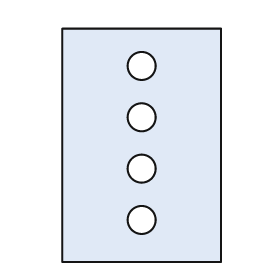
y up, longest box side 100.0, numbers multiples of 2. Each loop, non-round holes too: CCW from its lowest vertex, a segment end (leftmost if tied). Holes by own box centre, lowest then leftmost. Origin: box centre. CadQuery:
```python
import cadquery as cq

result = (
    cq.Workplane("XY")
    .moveTo(-34.0, -50.0)
    .lineTo(34.0, -50.0)
    .lineTo(34.0, 50.0)
    .lineTo(-34.0, 50.0)
    .close()
    .moveTo(0.0, -32.0)
    .circle(6.0)
    .moveTo(0.0, -10.0)
    .circle(6.0)
    .moveTo(0.0, 12.0)
    .circle(6.0)
    .moveTo(0.0, 34.0)
    .circle(6.0)
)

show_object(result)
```